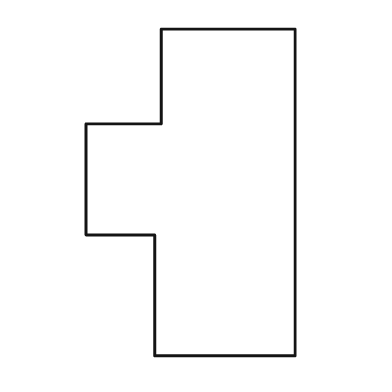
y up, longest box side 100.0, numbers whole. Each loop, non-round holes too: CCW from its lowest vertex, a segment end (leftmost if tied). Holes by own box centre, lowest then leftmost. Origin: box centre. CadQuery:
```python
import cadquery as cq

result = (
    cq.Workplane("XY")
    .moveTo(-11.0, -50.0)
    .lineTo(32.0, -50.0)
    .lineTo(32.0, 50.0)
    .lineTo(-9.0, 50.0)
    .lineTo(-9.0, 21.0)
    .lineTo(-32.0, 21.0)
    .lineTo(-32.0, -13.0)
    .lineTo(-11.0, -13.0)
    .close()
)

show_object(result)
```